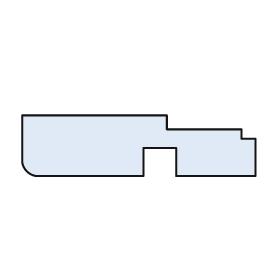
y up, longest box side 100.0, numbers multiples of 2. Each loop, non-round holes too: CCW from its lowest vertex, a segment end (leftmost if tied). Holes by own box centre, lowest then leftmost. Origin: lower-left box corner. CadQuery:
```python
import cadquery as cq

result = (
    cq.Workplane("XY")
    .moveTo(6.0, 0.0)
    .lineTo(52.0, 0.0)
    .lineTo(52.0, 12.0)
    .lineTo(66.0, 12.0)
    .lineTo(66.0, 0.0)
    .lineTo(100.0, 0.0)
    .lineTo(100.0, 16.0)
    .lineTo(94.0, 16.0)
    .lineTo(94.0, 20.0)
    .lineTo(62.0, 20.0)
    .lineTo(62.0, 26.0)
    .lineTo(0.0, 26.0)
    .lineTo(0.0, 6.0)
    .threePointArc((2.0, 2.0), (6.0, 0.0))
    .close()
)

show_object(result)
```